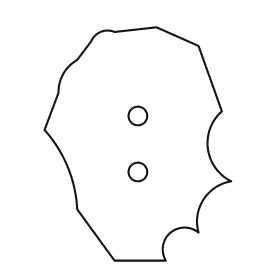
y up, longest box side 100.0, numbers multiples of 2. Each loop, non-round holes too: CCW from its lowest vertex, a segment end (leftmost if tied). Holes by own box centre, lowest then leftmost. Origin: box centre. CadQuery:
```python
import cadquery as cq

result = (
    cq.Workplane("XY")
    .moveTo(-10.0, -50.0)
    .lineTo(12.0, -50.0)
    .threePointArc((14.0, -38.0), (26.0, -38.0))
    .threePointArc((28.0, -24.0), (40.0, -16.0))
    .threePointArc((30.0, -2.0), (36.0, 14.0))
    .lineTo(26.0, 42.0)
    .lineTo(8.0, 50.0)
    .lineTo(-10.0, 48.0)
    .threePointArc((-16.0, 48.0), (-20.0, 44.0))
    .lineTo(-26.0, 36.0)
    .threePointArc((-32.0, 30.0), (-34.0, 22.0))
    .lineTo(-40.0, 6.0)
    .threePointArc((-30.0, -10.0), (-26.0, -28.0))
    .close()
    .moveTo(0.0, -12.0)
    .circle(4.0)
    .moveTo(0.0, 12.0)
    .circle(4.0)
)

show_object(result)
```